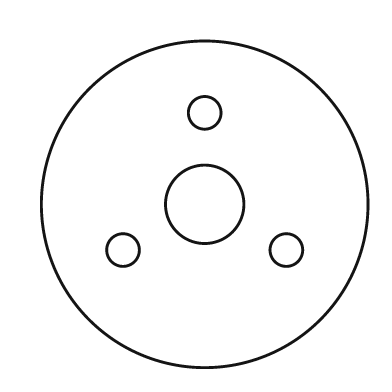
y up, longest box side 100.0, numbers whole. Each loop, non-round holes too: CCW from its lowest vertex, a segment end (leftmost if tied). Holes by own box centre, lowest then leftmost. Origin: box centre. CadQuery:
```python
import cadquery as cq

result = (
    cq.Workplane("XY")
    .moveTo(0.0, 0.0)
    .circle(50.0)
    .moveTo(-25.0, -14.0)
    .circle(5.0)
    .moveTo(25.0, -14.0)
    .circle(5.0)
    .moveTo(0.0, 0.0)
    .circle(12.0)
    .moveTo(0.0, 28.0)
    .circle(5.0)
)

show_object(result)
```